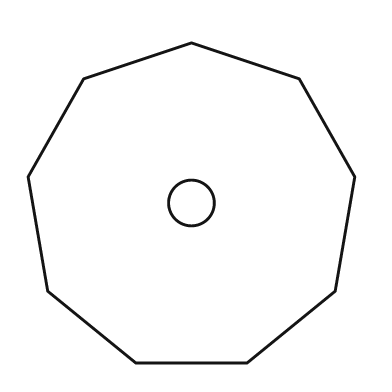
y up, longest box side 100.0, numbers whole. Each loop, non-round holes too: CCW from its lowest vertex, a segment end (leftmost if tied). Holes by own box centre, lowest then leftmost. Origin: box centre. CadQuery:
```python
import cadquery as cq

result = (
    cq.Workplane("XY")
    .moveTo(-17.0, -49.0)
    .lineTo(17.0, -49.0)
    .lineTo(44.0, -27.0)
    .lineTo(50.0, 8.0)
    .lineTo(33.0, 38.0)
    .lineTo(0.0, 49.0)
    .lineTo(-33.0, 38.0)
    .lineTo(-50.0, 8.0)
    .lineTo(-44.0, -27.0)
    .close()
    .moveTo(0.0, 0.0)
    .circle(7.0)
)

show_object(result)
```